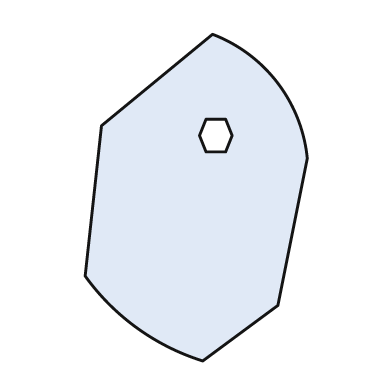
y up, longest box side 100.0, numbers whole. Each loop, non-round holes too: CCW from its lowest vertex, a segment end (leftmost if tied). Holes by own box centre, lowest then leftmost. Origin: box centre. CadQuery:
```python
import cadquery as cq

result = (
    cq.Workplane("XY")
    .moveTo(2.0, -50.0)
    .lineTo(25.0, -33.0)
    .lineTo(34.0, 12.0)
    .threePointArc((25.0, 35.0), (5.0, 50.0))
    .lineTo(-29.0, 22.0)
    .lineTo(-34.0, -24.0)
    .threePointArc((-18.0, -40.0), (2.0, -50.0))
    .close()
    .moveTo(3.0, 14.0)
    .lineTo(9.0, 14.0)
    .lineTo(11.0, 19.0)
    .lineTo(9.0, 24.0)
    .lineTo(3.0, 24.0)
    .lineTo(1.0, 19.0)
    .close()
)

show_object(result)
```